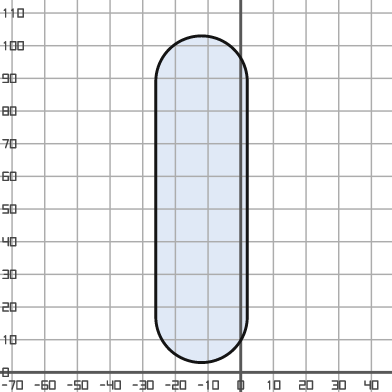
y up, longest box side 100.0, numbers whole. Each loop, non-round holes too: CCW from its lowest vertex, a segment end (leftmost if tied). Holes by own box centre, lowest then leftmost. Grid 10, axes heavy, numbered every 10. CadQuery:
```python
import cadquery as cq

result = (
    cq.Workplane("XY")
    .moveTo(-26.0, 17.0)
    .threePointArc((-12.0, 3.0), (2.0, 17.0))
    .lineTo(2.0, 89.0)
    .threePointArc((-12.0, 103.0), (-26.0, 89.0))
    .close()
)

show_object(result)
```